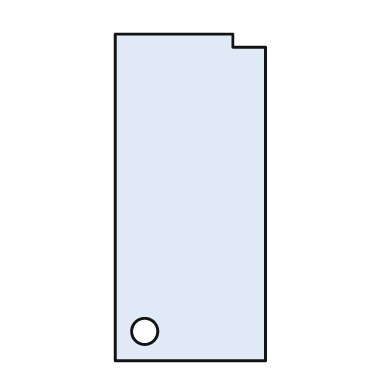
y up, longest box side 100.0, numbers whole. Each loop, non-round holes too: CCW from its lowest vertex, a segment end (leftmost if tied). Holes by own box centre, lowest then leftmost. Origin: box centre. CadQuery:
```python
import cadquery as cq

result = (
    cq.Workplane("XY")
    .moveTo(-23.0, -50.0)
    .lineTo(23.0, -50.0)
    .lineTo(23.0, 46.0)
    .lineTo(13.0, 46.0)
    .lineTo(13.0, 50.0)
    .lineTo(-23.0, 50.0)
    .close()
    .moveTo(-14.0, -41.0)
    .circle(4.0)
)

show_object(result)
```